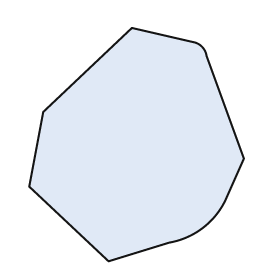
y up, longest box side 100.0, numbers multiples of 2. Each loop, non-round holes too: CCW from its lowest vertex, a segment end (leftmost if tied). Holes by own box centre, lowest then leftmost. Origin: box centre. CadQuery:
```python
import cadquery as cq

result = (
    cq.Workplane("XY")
    .moveTo(-12.0, -50.0)
    .lineTo(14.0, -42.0)
    .threePointArc((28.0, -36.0), (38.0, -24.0))
    .lineTo(46.0, -6.0)
    .lineTo(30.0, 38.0)
    .threePointArc((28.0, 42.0), (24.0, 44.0))
    .lineTo(-2.0, 50.0)
    .lineTo(-40.0, 14.0)
    .lineTo(-46.0, -18.0)
    .close()
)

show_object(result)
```